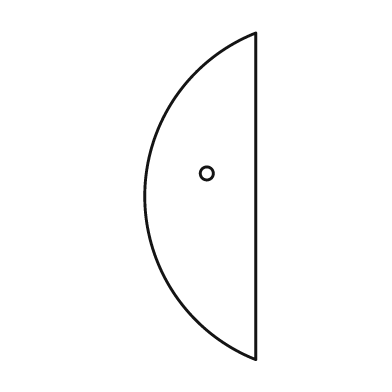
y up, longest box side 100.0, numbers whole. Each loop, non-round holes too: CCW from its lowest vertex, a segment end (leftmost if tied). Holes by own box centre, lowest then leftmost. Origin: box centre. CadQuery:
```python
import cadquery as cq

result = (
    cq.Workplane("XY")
    .moveTo(17.0, -50.0)
    .lineTo(17.0, 50.0)
    .threePointArc((-17.0, 0.0), (17.0, -50.0))
    .close()
    .moveTo(2.0, 7.0)
    .circle(2.0)
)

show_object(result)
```